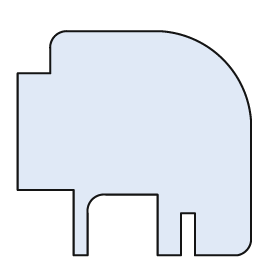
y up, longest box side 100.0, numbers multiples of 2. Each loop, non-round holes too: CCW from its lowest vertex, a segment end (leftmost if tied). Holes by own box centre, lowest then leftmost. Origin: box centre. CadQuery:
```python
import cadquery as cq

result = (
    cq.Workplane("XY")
    .moveTo(-26.0, -48.0)
    .lineTo(-20.0, -48.0)
    .lineTo(-20.0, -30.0)
    .threePointArc((-18.0, -24.0), (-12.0, -22.0))
    .lineTo(10.0, -22.0)
    .lineTo(10.0, -48.0)
    .lineTo(20.0, -48.0)
    .lineTo(20.0, -30.0)
    .lineTo(26.0, -30.0)
    .lineTo(26.0, -48.0)
    .lineTo(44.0, -48.0)
    .threePointArc((48.0, -46.0), (50.0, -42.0))
    .lineTo(50.0, 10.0)
    .threePointArc((38.0, 36.0), (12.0, 48.0))
    .lineTo(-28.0, 48.0)
    .threePointArc((-34.0, 46.0), (-36.0, 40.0))
    .lineTo(-36.0, 30.0)
    .lineTo(-50.0, 30.0)
    .lineTo(-50.0, -20.0)
    .lineTo(-26.0, -20.0)
    .close()
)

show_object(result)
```